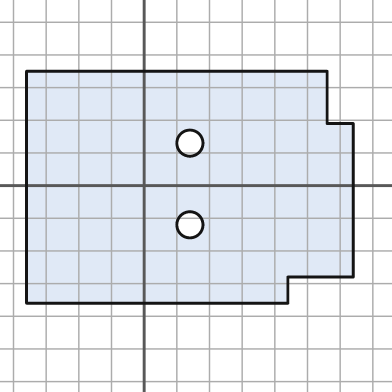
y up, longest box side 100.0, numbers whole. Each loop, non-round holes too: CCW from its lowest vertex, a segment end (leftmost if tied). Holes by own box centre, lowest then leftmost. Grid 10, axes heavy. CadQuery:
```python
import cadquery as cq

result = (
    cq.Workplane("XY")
    .moveTo(-36.0, -36.0)
    .lineTo(44.0, -36.0)
    .lineTo(44.0, -28.0)
    .lineTo(64.0, -28.0)
    .lineTo(64.0, 19.0)
    .lineTo(56.0, 19.0)
    .lineTo(56.0, 35.0)
    .lineTo(-36.0, 35.0)
    .close()
    .moveTo(14.0, -12.0)
    .circle(4.0)
    .moveTo(14.0, 13.0)
    .circle(4.0)
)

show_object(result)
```